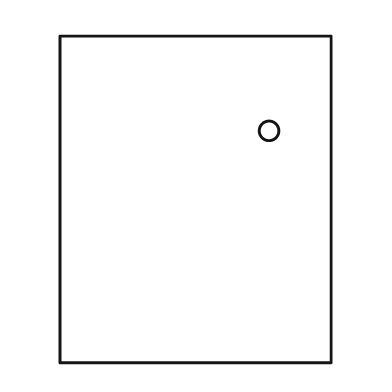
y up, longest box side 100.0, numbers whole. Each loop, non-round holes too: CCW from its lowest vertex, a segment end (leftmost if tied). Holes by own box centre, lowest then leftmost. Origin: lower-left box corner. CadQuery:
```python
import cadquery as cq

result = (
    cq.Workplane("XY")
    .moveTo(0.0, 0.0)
    .lineTo(83.0, 0.0)
    .lineTo(83.0, 100.0)
    .lineTo(0.0, 100.0)
    .close()
    .moveTo(64.0, 71.0)
    .circle(3.0)
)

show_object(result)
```